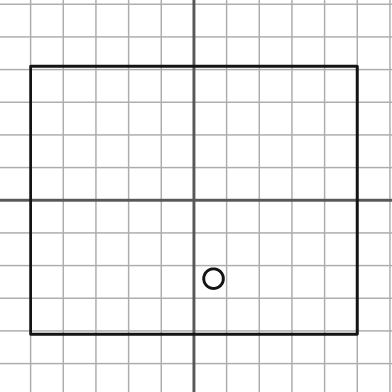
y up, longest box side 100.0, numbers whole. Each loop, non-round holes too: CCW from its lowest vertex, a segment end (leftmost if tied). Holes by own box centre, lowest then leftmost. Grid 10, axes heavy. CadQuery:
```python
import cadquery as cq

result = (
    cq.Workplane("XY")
    .moveTo(-50.0, -41.0)
    .lineTo(50.0, -41.0)
    .lineTo(50.0, 41.0)
    .lineTo(-50.0, 41.0)
    .close()
    .moveTo(6.0, -24.0)
    .circle(3.0)
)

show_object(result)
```